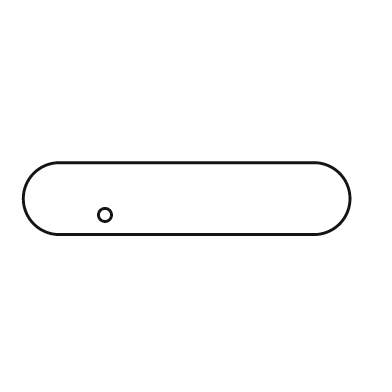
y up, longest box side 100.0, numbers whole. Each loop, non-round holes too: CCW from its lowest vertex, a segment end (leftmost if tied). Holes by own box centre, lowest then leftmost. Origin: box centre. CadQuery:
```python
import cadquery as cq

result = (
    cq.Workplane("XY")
    .moveTo(-39.0, -11.0)
    .lineTo(39.0, -11.0)
    .threePointArc((50.0, 0.0), (39.0, 11.0))
    .lineTo(-39.0, 11.0)
    .threePointArc((-50.0, 0.0), (-39.0, -11.0))
    .close()
    .moveTo(-25.0, -5.0)
    .circle(2.0)
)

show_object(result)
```